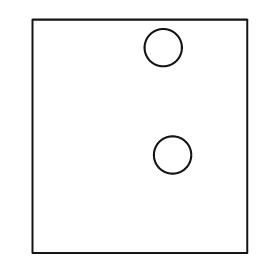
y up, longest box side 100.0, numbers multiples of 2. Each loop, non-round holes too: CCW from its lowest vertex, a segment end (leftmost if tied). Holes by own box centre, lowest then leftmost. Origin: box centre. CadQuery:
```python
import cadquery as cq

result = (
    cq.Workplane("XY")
    .moveTo(-46.0, -50.0)
    .lineTo(46.0, -50.0)
    .lineTo(46.0, 50.0)
    .lineTo(-46.0, 50.0)
    .close()
    .moveTo(14.0, -8.0)
    .circle(8.0)
    .moveTo(10.0, 38.0)
    .circle(8.0)
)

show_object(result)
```